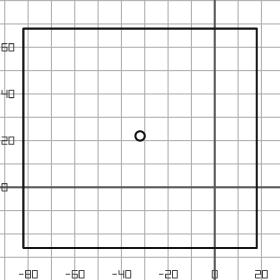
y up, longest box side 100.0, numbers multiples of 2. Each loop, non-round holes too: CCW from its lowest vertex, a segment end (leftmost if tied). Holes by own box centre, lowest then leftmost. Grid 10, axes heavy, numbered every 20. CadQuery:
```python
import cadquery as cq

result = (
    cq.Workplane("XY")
    .moveTo(-82.0, -26.0)
    .lineTo(18.0, -26.0)
    .lineTo(18.0, 68.0)
    .lineTo(-82.0, 68.0)
    .close()
    .moveTo(-32.0, 22.0)
    .circle(2.0)
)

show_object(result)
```